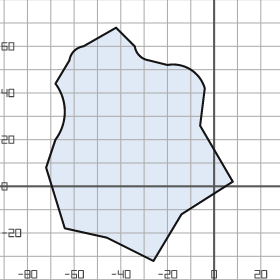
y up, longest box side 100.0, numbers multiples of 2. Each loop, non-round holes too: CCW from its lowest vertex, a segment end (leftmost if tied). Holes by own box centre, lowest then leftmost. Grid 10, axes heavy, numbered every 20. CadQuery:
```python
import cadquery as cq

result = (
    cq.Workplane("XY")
    .moveTo(-26.0, -32.0)
    .lineTo(-14.0, -12.0)
    .lineTo(8.0, 2.0)
    .lineTo(-6.0, 26.0)
    .lineTo(-4.0, 42.0)
    .threePointArc((-10.0, 50.0), (-20.0, 52.0))
    .lineTo(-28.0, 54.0)
    .threePointArc((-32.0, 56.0), (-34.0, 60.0))
    .lineTo(-42.0, 68.0)
    .lineTo(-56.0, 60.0)
    .threePointArc((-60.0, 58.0), (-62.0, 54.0))
    .lineTo(-68.0, 44.0)
    .threePointArc((-64.0, 32.0), (-68.0, 20.0))
    .lineTo(-72.0, 8.0)
    .lineTo(-64.0, -18.0)
    .lineTo(-46.0, -22.0)
    .close()
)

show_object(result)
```